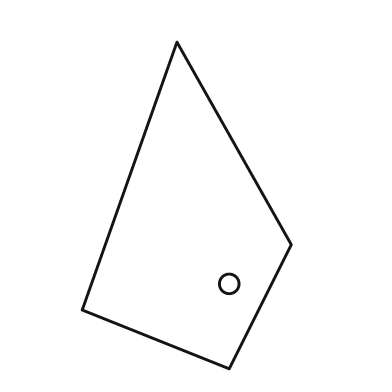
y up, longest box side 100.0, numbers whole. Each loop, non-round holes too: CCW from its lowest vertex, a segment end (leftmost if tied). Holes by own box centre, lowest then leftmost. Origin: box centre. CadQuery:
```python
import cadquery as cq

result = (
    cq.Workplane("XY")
    .moveTo(13.0, -50.0)
    .lineTo(32.0, -12.0)
    .lineTo(-3.0, 50.0)
    .lineTo(-32.0, -32.0)
    .close()
    .moveTo(13.0, -24.0)
    .circle(3.0)
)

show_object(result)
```